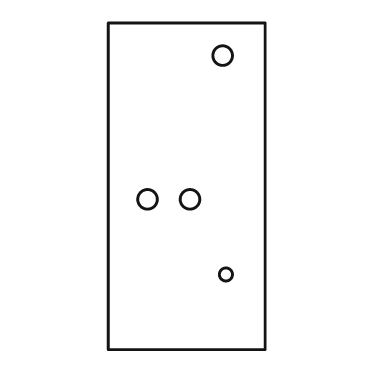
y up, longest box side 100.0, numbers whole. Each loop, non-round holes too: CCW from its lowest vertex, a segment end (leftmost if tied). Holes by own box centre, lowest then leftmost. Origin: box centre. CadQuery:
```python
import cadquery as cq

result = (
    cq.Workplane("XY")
    .moveTo(-24.0, -50.0)
    .lineTo(24.0, -50.0)
    .lineTo(24.0, 50.0)
    .lineTo(-24.0, 50.0)
    .close()
    .moveTo(12.0, -27.0)
    .circle(2.0)
    .moveTo(-12.0, -4.0)
    .circle(3.0)
    .moveTo(1.0, -4.0)
    .circle(3.0)
    .moveTo(11.0, 40.0)
    .circle(3.0)
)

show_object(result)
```